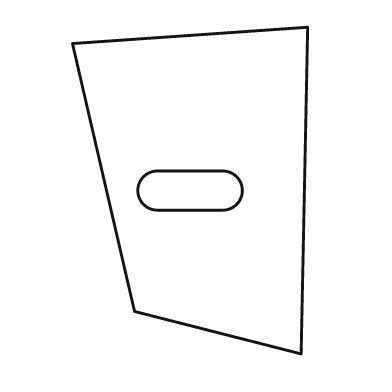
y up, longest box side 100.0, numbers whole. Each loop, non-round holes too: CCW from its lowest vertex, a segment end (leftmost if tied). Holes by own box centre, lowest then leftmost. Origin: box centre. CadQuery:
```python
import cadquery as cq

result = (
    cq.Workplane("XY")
    .moveTo(34.0, -50.0)
    .lineTo(36.0, 50.0)
    .lineTo(-36.0, 45.0)
    .lineTo(-17.0, -37.0)
    .close()
    .moveTo(-10.0, -6.0)
    .lineTo(10.0, -6.0)
    .threePointArc((16.0, 0.0), (10.0, 6.0))
    .lineTo(-10.0, 6.0)
    .threePointArc((-16.0, 0.0), (-10.0, -6.0))
    .close()
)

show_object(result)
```